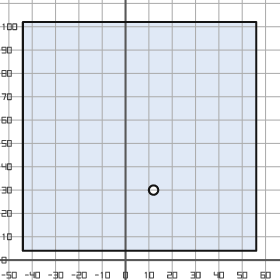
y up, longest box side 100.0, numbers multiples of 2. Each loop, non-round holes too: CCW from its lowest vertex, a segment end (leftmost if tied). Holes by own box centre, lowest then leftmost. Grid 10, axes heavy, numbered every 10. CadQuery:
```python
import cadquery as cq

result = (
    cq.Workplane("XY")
    .moveTo(-44.0, 4.0)
    .lineTo(56.0, 4.0)
    .lineTo(56.0, 102.0)
    .lineTo(-44.0, 102.0)
    .close()
    .moveTo(12.0, 30.0)
    .circle(2.0)
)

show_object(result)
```